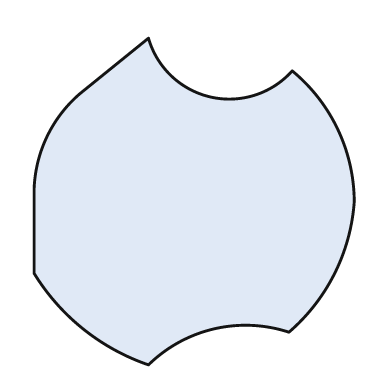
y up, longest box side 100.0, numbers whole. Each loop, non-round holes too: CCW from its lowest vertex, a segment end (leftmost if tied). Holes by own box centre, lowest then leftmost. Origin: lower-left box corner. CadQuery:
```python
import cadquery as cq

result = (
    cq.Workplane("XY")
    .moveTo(35.0, 0.0)
    .threePointArc((55.0, 11.0), (78.0, 10.0))
    .threePointArc((92.0, 28.0), (98.0, 50.0))
    .threePointArc((93.0, 72.0), (79.0, 90.0))
    .threePointArc((54.0, 82.0), (35.0, 100.0))
    .lineTo(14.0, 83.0)
    .threePointArc((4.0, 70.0), (0.0, 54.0))
    .lineTo(0.0, 28.0)
    .threePointArc((15.0, 11.0), (35.0, 0.0))
    .close()
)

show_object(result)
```